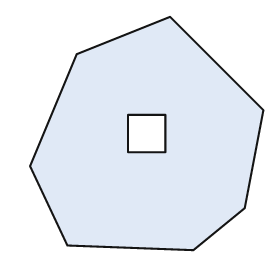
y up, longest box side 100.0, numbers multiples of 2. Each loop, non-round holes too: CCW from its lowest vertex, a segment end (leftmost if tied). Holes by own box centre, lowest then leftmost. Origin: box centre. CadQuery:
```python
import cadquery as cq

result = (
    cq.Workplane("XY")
    .moveTo(20.0, -50.0)
    .lineTo(42.0, -32.0)
    .lineTo(50.0, 10.0)
    .lineTo(10.0, 50.0)
    .lineTo(-30.0, 34.0)
    .lineTo(-50.0, -14.0)
    .lineTo(-34.0, -48.0)
    .close()
    .moveTo(-8.0, -8.0)
    .lineTo(8.0, -8.0)
    .lineTo(8.0, 8.0)
    .lineTo(-8.0, 8.0)
    .close()
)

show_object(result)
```